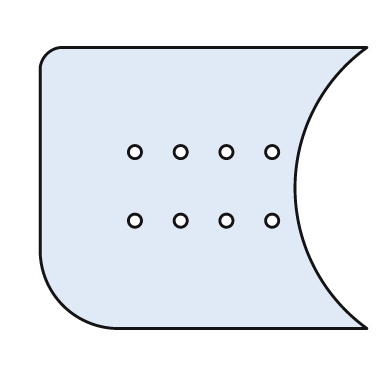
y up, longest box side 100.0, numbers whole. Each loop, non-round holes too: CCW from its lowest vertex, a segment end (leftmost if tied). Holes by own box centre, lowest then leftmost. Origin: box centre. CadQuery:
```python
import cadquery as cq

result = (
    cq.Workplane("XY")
    .moveTo(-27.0, -43.0)
    .lineTo(50.0, -43.0)
    .threePointArc((28.0, 0.0), (50.0, 43.0))
    .lineTo(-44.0, 43.0)
    .threePointArc((-48.0, 41.0), (-50.0, 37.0))
    .lineTo(-50.0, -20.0)
    .threePointArc((-43.0, -36.0), (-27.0, -43.0))
    .close()
    .moveTo(-21.0, -10.0)
    .circle(2.0)
    .moveTo(-7.0, -10.0)
    .circle(2.0)
    .moveTo(7.0, -10.0)
    .circle(2.0)
    .moveTo(21.0, -10.0)
    .circle(2.0)
    .moveTo(-21.0, 11.0)
    .circle(2.0)
    .moveTo(-7.0, 11.0)
    .circle(2.0)
    .moveTo(7.0, 11.0)
    .circle(2.0)
    .moveTo(21.0, 11.0)
    .circle(2.0)
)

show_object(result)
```